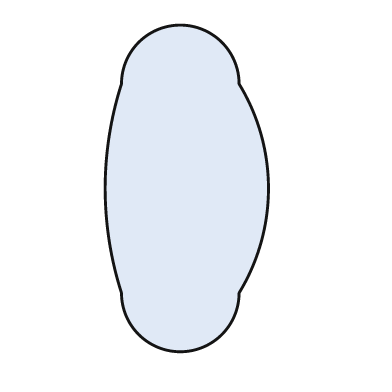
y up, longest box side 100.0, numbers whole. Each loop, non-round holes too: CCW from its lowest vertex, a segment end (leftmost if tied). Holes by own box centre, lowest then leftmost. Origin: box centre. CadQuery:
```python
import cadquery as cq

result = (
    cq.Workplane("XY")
    .moveTo(-20.0, -32.0)
    .threePointArc((-2.0, -50.0), (16.0, -32.0))
    .threePointArc((25.0, 0.0), (16.0, 32.0))
    .threePointArc((-2.0, 50.0), (-20.0, 32.0))
    .threePointArc((-25.0, 0.0), (-20.0, -32.0))
    .close()
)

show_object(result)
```